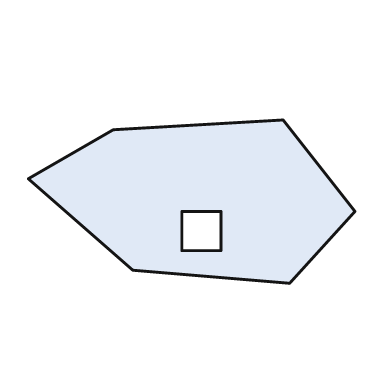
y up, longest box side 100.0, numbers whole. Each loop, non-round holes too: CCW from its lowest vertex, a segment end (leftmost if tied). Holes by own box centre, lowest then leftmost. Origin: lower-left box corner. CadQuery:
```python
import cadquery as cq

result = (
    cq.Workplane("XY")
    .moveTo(80.0, 0.0)
    .lineTo(100.0, 22.0)
    .lineTo(78.0, 50.0)
    .lineTo(26.0, 47.0)
    .lineTo(0.0, 32.0)
    .lineTo(32.0, 4.0)
    .close()
    .moveTo(47.0, 10.0)
    .lineTo(59.0, 10.0)
    .lineTo(59.0, 22.0)
    .lineTo(47.0, 22.0)
    .close()
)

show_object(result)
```